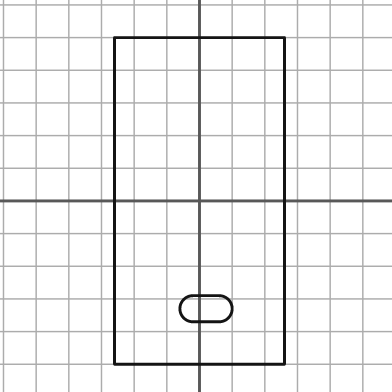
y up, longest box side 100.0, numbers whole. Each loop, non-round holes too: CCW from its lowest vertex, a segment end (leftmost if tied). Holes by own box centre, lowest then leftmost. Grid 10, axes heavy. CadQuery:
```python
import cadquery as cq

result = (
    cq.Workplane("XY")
    .moveTo(-26.0, -50.0)
    .lineTo(26.0, -50.0)
    .lineTo(26.0, 50.0)
    .lineTo(-26.0, 50.0)
    .close()
    .moveTo(-2.0, -37.0)
    .lineTo(6.0, -37.0)
    .threePointArc((10.0, -33.0), (6.0, -29.0))
    .lineTo(-2.0, -29.0)
    .threePointArc((-6.0, -33.0), (-2.0, -37.0))
    .close()
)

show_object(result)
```